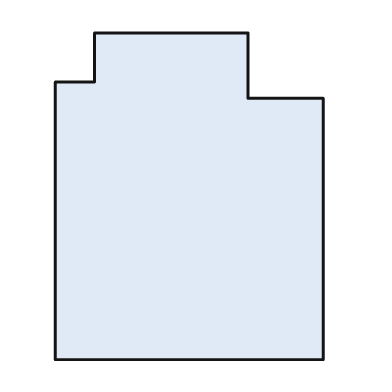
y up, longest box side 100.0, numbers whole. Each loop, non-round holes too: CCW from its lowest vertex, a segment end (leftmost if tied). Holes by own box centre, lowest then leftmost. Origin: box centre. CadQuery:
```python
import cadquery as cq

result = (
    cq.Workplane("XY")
    .moveTo(-41.0, -50.0)
    .lineTo(41.0, -50.0)
    .lineTo(41.0, 30.0)
    .lineTo(18.0, 30.0)
    .lineTo(18.0, 50.0)
    .lineTo(-29.0, 50.0)
    .lineTo(-29.0, 35.0)
    .lineTo(-41.0, 35.0)
    .close()
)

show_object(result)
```